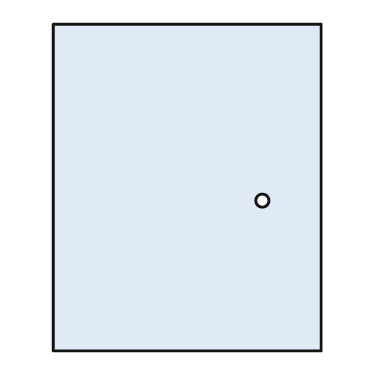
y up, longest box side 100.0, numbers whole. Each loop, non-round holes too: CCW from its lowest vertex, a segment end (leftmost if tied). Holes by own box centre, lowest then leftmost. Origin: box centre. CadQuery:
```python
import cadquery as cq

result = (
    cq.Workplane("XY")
    .moveTo(-41.0, -50.0)
    .lineTo(41.0, -50.0)
    .lineTo(41.0, 50.0)
    .lineTo(-41.0, 50.0)
    .close()
    .moveTo(23.0, -4.0)
    .circle(2.0)
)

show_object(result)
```